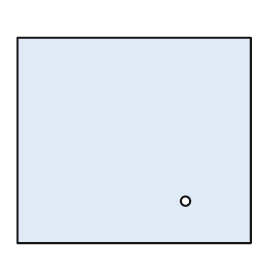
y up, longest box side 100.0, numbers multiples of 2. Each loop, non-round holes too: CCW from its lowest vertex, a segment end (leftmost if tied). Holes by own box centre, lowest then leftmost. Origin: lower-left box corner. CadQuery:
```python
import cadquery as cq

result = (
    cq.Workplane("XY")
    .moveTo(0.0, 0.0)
    .lineTo(100.0, 0.0)
    .lineTo(100.0, 88.0)
    .lineTo(0.0, 88.0)
    .close()
    .moveTo(72.0, 18.0)
    .circle(2.0)
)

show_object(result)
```